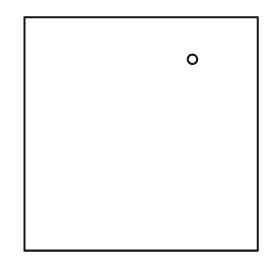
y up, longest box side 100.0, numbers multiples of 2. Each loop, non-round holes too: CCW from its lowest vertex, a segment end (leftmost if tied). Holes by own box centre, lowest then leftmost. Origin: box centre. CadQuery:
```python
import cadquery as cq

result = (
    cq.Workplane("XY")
    .moveTo(-50.0, -50.0)
    .lineTo(50.0, -50.0)
    .lineTo(50.0, 50.0)
    .lineTo(-50.0, 50.0)
    .close()
    .moveTo(22.0, 32.0)
    .circle(2.0)
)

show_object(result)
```